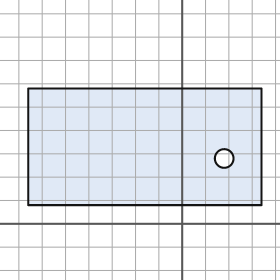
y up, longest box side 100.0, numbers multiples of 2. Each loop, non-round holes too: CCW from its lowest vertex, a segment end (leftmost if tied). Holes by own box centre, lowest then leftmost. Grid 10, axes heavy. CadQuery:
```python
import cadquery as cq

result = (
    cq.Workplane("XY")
    .moveTo(-66.0, 8.0)
    .lineTo(34.0, 8.0)
    .lineTo(34.0, 58.0)
    .lineTo(-66.0, 58.0)
    .close()
    .moveTo(18.0, 28.0)
    .circle(4.0)
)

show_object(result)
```